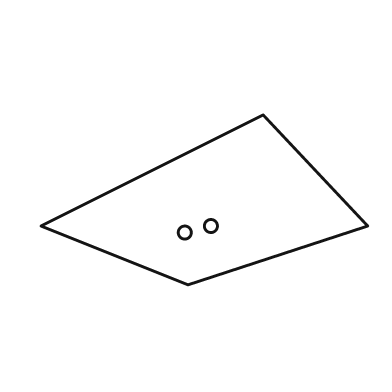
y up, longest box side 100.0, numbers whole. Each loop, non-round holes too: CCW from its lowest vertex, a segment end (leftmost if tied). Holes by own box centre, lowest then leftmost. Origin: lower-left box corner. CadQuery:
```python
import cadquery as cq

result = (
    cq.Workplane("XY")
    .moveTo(45.0, 0.0)
    .lineTo(100.0, 18.0)
    .lineTo(68.0, 52.0)
    .lineTo(0.0, 18.0)
    .close()
    .moveTo(44.0, 16.0)
    .circle(2.0)
    .moveTo(52.0, 18.0)
    .circle(2.0)
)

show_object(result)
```